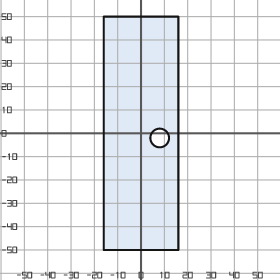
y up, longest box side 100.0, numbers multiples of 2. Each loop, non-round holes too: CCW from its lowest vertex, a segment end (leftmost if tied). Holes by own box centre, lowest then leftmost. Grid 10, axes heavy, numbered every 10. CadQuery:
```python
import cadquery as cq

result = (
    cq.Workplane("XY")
    .moveTo(-16.0, -50.0)
    .lineTo(16.0, -50.0)
    .lineTo(16.0, 50.0)
    .lineTo(-16.0, 50.0)
    .close()
    .moveTo(8.0, -2.0)
    .circle(4.0)
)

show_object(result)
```